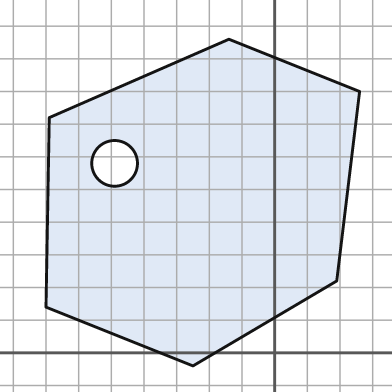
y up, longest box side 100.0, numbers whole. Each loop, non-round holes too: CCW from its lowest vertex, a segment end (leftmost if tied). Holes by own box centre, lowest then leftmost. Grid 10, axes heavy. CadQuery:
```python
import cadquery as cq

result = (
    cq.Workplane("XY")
    .moveTo(-25.0, -4.0)
    .lineTo(19.0, 22.0)
    .lineTo(26.0, 80.0)
    .lineTo(-14.0, 96.0)
    .lineTo(-69.0, 72.0)
    .lineTo(-70.0, 14.0)
    .close()
    .moveTo(-49.0, 58.0)
    .circle(7.0)
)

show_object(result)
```